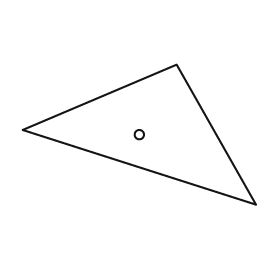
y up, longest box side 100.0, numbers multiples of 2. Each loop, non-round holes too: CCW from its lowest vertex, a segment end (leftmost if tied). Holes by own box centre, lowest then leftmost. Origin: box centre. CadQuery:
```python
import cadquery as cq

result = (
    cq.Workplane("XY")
    .moveTo(50.0, -30.0)
    .lineTo(16.0, 30.0)
    .lineTo(-50.0, 2.0)
    .close()
    .moveTo(0.0, 0.0)
    .circle(2.0)
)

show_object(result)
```